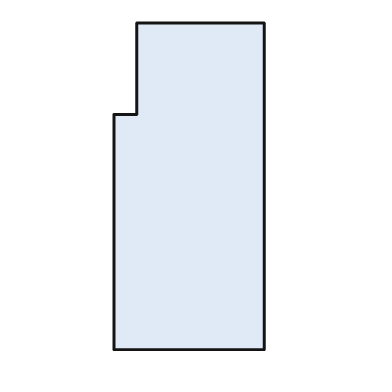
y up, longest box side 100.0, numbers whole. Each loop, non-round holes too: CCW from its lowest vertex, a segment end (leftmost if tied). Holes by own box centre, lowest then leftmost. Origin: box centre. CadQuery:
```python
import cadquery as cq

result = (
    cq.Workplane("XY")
    .moveTo(-23.0, -50.0)
    .lineTo(23.0, -50.0)
    .lineTo(23.0, 50.0)
    .lineTo(-16.0, 50.0)
    .lineTo(-16.0, 22.0)
    .lineTo(-23.0, 22.0)
    .close()
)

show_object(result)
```